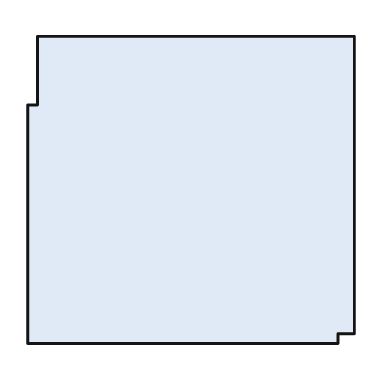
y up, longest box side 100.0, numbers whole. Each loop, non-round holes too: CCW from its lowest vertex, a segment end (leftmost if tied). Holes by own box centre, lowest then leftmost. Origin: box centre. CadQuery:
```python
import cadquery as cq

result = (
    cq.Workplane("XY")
    .moveTo(-50.0, -47.0)
    .lineTo(45.0, -47.0)
    .lineTo(45.0, -44.0)
    .lineTo(50.0, -44.0)
    .lineTo(50.0, 47.0)
    .lineTo(-47.0, 47.0)
    .lineTo(-47.0, 26.0)
    .lineTo(-50.0, 26.0)
    .close()
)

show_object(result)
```